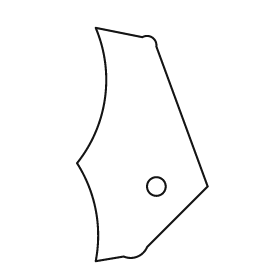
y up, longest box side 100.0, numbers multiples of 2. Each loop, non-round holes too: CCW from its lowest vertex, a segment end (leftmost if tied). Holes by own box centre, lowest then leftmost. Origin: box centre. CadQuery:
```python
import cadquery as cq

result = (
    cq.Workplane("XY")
    .moveTo(-20.0, -50.0)
    .lineTo(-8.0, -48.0)
    .threePointArc((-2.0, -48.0), (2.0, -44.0))
    .lineTo(28.0, -18.0)
    .lineTo(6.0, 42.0)
    .threePointArc((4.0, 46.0), (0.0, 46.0))
    .lineTo(-20.0, 50.0)
    .threePointArc((-16.0, 20.0), (-28.0, -8.0))
    .threePointArc((-20.0, -28.0), (-20.0, -50.0))
    .close()
    .moveTo(6.0, -18.0)
    .circle(4.0)
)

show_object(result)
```